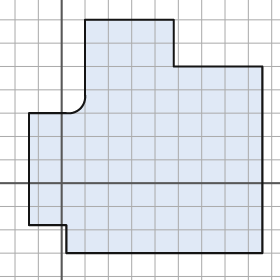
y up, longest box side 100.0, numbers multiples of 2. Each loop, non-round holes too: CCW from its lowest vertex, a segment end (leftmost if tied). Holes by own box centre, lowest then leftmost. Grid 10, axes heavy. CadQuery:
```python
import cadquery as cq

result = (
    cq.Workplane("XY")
    .moveTo(2.0, -30.0)
    .lineTo(86.0, -30.0)
    .lineTo(86.0, 50.0)
    .lineTo(48.0, 50.0)
    .lineTo(48.0, 70.0)
    .lineTo(10.0, 70.0)
    .lineTo(10.0, 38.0)
    .threePointArc((8.0, 32.0), (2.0, 30.0))
    .lineTo(-14.0, 30.0)
    .lineTo(-14.0, -18.0)
    .lineTo(2.0, -18.0)
    .close()
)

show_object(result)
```